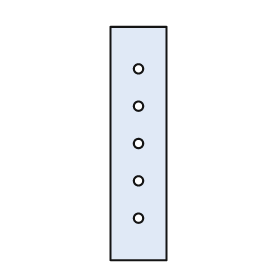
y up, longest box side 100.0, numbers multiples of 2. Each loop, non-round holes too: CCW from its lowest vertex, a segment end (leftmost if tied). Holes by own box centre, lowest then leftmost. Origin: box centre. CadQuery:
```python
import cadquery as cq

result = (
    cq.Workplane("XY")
    .moveTo(-12.0, -50.0)
    .lineTo(12.0, -50.0)
    .lineTo(12.0, 50.0)
    .lineTo(-12.0, 50.0)
    .close()
    .moveTo(0.0, -32.0)
    .circle(2.0)
    .moveTo(0.0, -16.0)
    .circle(2.0)
    .moveTo(0.0, 0.0)
    .circle(2.0)
    .moveTo(0.0, 16.0)
    .circle(2.0)
    .moveTo(0.0, 32.0)
    .circle(2.0)
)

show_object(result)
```